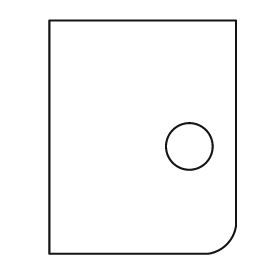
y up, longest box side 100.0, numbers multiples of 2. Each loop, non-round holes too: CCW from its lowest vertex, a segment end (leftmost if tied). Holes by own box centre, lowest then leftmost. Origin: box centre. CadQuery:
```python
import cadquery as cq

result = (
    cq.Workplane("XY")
    .moveTo(-40.0, -50.0)
    .lineTo(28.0, -50.0)
    .threePointArc((36.0, -46.0), (40.0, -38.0))
    .lineTo(40.0, 50.0)
    .lineTo(-40.0, 50.0)
    .close()
    .moveTo(20.0, -4.0)
    .circle(10.0)
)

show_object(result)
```